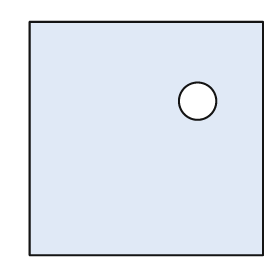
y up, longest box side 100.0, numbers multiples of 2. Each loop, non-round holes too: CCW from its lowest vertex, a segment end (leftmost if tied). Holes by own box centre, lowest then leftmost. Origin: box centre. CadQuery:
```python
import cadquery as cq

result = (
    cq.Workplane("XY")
    .moveTo(-50.0, -50.0)
    .lineTo(50.0, -50.0)
    .lineTo(50.0, 50.0)
    .lineTo(-50.0, 50.0)
    .close()
    .moveTo(22.0, 16.0)
    .circle(8.0)
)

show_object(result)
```